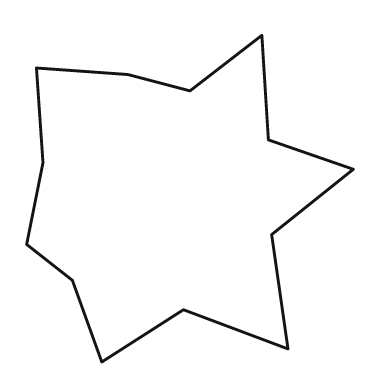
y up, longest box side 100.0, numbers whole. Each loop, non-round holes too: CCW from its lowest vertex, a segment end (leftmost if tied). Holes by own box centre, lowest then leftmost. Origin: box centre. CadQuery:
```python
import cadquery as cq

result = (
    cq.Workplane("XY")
    .moveTo(-27.0, -50.0)
    .lineTo(-2.0, -34.0)
    .lineTo(30.0, -46.0)
    .lineTo(25.0, -11.0)
    .lineTo(50.0, 9.0)
    .lineTo(24.0, 18.0)
    .lineTo(22.0, 50.0)
    .lineTo(0.0, 33.0)
    .lineTo(-19.0, 38.0)
    .lineTo(-47.0, 40.0)
    .lineTo(-45.0, 11.0)
    .lineTo(-50.0, -14.0)
    .lineTo(-36.0, -25.0)
    .close()
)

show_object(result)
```